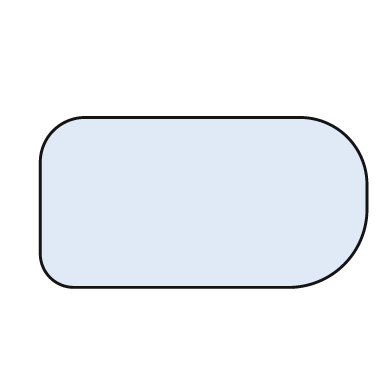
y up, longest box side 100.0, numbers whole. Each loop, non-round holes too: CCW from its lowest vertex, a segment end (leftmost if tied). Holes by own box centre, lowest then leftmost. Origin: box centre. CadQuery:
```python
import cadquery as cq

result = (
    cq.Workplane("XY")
    .moveTo(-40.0, -26.0)
    .lineTo(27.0, -26.0)
    .threePointArc((43.0, -19.0), (50.0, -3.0))
    .lineTo(50.0, 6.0)
    .threePointArc((44.0, 20.0), (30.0, 26.0))
    .lineTo(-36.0, 26.0)
    .threePointArc((-46.0, 22.0), (-50.0, 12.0))
    .lineTo(-50.0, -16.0)
    .threePointArc((-47.0, -23.0), (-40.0, -26.0))
    .close()
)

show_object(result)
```